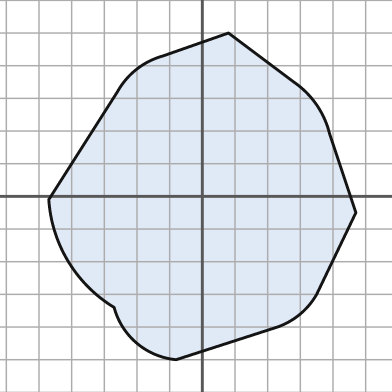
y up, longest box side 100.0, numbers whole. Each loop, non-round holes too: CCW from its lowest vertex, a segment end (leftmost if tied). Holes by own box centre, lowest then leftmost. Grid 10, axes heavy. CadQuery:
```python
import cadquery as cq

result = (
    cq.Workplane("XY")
    .moveTo(-8.0, -50.0)
    .lineTo(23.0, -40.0)
    .threePointArc((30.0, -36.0), (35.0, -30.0))
    .lineTo(47.0, -5.0)
    .lineTo(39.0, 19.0)
    .threePointArc((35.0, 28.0), (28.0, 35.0))
    .lineTo(8.0, 50.0)
    .lineTo(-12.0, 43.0)
    .threePointArc((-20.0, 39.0), (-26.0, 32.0))
    .lineTo(-47.0, -1.0)
    .threePointArc((-41.0, -20.0), (-27.0, -34.0))
    .threePointArc((-20.0, -45.0), (-8.0, -50.0))
    .close()
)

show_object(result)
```